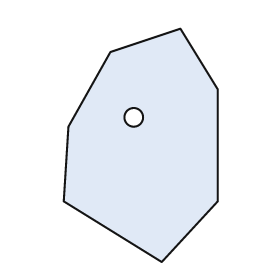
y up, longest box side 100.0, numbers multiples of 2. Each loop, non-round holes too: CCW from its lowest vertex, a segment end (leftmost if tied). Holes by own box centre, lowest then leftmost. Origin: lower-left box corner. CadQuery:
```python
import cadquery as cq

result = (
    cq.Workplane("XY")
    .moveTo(42.0, 0.0)
    .lineTo(66.0, 26.0)
    .lineTo(66.0, 74.0)
    .lineTo(50.0, 100.0)
    .lineTo(20.0, 90.0)
    .lineTo(2.0, 58.0)
    .lineTo(0.0, 26.0)
    .close()
    .moveTo(30.0, 62.0)
    .circle(4.0)
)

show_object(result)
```